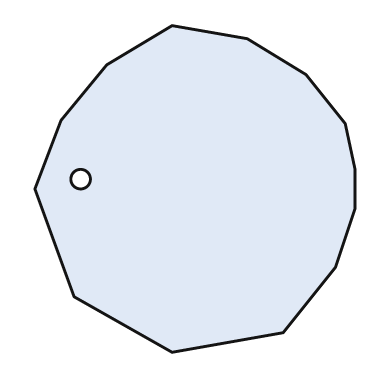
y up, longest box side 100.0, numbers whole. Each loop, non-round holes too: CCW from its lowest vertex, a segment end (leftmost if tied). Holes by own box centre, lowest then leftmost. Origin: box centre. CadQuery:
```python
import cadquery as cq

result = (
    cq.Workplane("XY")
    .moveTo(-7.0, -50.0)
    .lineTo(27.0, -44.0)
    .lineTo(43.0, -24.0)
    .lineTo(49.0, -6.0)
    .lineTo(49.0, 6.0)
    .lineTo(46.0, 20.0)
    .lineTo(34.0, 35.0)
    .lineTo(16.0, 46.0)
    .lineTo(-7.0, 50.0)
    .lineTo(-27.0, 38.0)
    .lineTo(-41.0, 21.0)
    .lineTo(-49.0, 0.0)
    .lineTo(-37.0, -33.0)
    .close()
    .moveTo(-35.0, 3.0)
    .circle(3.0)
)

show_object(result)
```